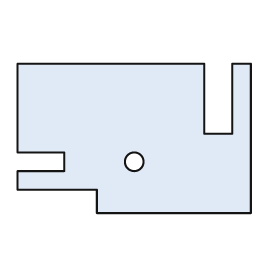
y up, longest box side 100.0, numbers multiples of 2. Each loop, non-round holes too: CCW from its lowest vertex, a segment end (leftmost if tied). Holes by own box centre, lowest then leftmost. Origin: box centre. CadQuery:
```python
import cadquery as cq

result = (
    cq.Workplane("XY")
    .moveTo(-16.0, -32.0)
    .lineTo(50.0, -32.0)
    .lineTo(50.0, 32.0)
    .lineTo(42.0, 32.0)
    .lineTo(42.0, 2.0)
    .lineTo(30.0, 2.0)
    .lineTo(30.0, 32.0)
    .lineTo(-50.0, 32.0)
    .lineTo(-50.0, -6.0)
    .lineTo(-30.0, -6.0)
    .lineTo(-30.0, -14.0)
    .lineTo(-50.0, -14.0)
    .lineTo(-50.0, -22.0)
    .lineTo(-16.0, -22.0)
    .close()
    .moveTo(0.0, -10.0)
    .circle(4.0)
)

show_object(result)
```